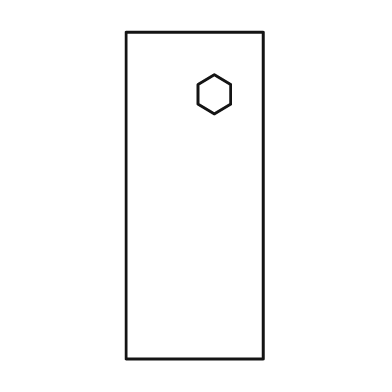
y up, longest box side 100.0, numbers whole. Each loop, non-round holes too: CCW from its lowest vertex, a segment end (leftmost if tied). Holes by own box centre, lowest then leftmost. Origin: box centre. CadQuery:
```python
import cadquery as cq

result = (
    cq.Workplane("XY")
    .moveTo(-21.0, -50.0)
    .lineTo(21.0, -50.0)
    .lineTo(21.0, 50.0)
    .lineTo(-21.0, 50.0)
    .close()
    .moveTo(6.0, 25.0)
    .lineTo(11.0, 28.0)
    .lineTo(11.0, 34.0)
    .lineTo(6.0, 37.0)
    .lineTo(1.0, 34.0)
    .lineTo(1.0, 28.0)
    .close()
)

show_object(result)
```